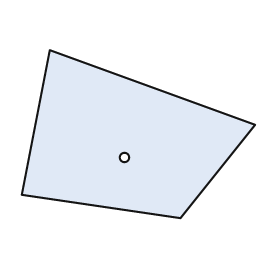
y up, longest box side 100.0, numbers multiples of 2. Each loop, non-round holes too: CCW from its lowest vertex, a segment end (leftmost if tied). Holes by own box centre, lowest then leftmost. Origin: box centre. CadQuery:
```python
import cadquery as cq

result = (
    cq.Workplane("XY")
    .moveTo(18.0, -36.0)
    .lineTo(50.0, 4.0)
    .lineTo(-38.0, 36.0)
    .lineTo(-50.0, -26.0)
    .close()
    .moveTo(-6.0, -10.0)
    .circle(2.0)
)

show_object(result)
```